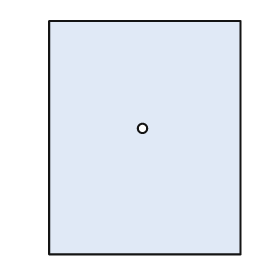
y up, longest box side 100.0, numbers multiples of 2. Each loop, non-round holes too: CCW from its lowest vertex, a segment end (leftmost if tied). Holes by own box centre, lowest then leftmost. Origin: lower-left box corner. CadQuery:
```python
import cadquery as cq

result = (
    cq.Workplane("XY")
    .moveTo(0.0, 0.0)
    .lineTo(82.0, 0.0)
    .lineTo(82.0, 100.0)
    .lineTo(0.0, 100.0)
    .close()
    .moveTo(40.0, 54.0)
    .circle(2.0)
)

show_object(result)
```